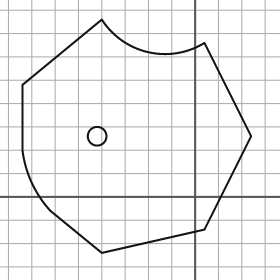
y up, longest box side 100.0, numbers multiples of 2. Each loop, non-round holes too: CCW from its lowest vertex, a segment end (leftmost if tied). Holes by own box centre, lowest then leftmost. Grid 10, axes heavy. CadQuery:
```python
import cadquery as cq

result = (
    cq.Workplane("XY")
    .moveTo(-40.0, -24.0)
    .lineTo(4.0, -14.0)
    .lineTo(24.0, 26.0)
    .lineTo(4.0, 66.0)
    .threePointArc((-20.0, 62.0), (-40.0, 76.0))
    .lineTo(-74.0, 48.0)
    .lineTo(-74.0, 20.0)
    .threePointArc((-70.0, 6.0), (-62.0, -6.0))
    .close()
    .moveTo(-42.0, 26.0)
    .circle(4.0)
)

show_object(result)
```